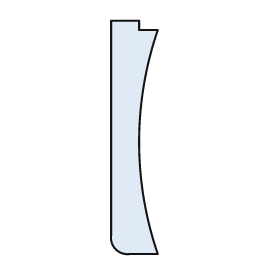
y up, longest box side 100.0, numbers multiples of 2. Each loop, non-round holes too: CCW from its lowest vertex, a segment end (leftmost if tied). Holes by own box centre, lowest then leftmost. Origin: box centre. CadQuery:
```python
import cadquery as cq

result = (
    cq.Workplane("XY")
    .moveTo(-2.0, -50.0)
    .lineTo(10.0, -50.0)
    .threePointArc((2.0, -2.0), (10.0, 46.0))
    .lineTo(2.0, 46.0)
    .lineTo(2.0, 50.0)
    .lineTo(-10.0, 50.0)
    .lineTo(-10.0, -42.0)
    .threePointArc((-8.0, -48.0), (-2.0, -50.0))
    .close()
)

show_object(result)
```